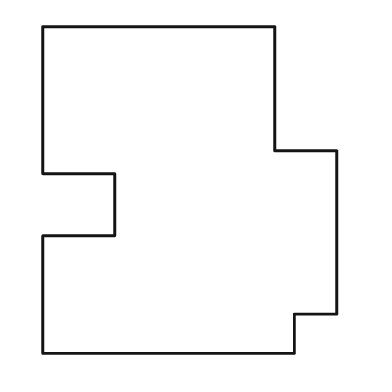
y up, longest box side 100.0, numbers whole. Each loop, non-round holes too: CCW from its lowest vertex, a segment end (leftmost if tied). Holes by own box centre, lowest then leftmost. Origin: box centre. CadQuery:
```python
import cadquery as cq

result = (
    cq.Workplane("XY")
    .moveTo(-45.0, -50.0)
    .lineTo(32.0, -50.0)
    .lineTo(32.0, -38.0)
    .lineTo(45.0, -38.0)
    .lineTo(45.0, 12.0)
    .lineTo(26.0, 12.0)
    .lineTo(26.0, 50.0)
    .lineTo(-45.0, 50.0)
    .lineTo(-45.0, 5.0)
    .lineTo(-23.0, 5.0)
    .lineTo(-23.0, -14.0)
    .lineTo(-45.0, -14.0)
    .close()
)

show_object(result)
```